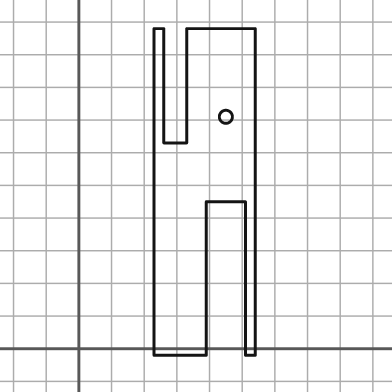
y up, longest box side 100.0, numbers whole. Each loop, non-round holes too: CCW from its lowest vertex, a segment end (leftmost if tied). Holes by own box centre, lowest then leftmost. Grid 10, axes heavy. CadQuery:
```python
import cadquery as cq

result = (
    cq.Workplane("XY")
    .moveTo(23.0, -2.0)
    .lineTo(39.0, -2.0)
    .lineTo(39.0, 45.0)
    .lineTo(51.0, 45.0)
    .lineTo(51.0, -2.0)
    .lineTo(54.0, -2.0)
    .lineTo(54.0, 98.0)
    .lineTo(33.0, 98.0)
    .lineTo(33.0, 63.0)
    .lineTo(26.0, 63.0)
    .lineTo(26.0, 98.0)
    .lineTo(23.0, 98.0)
    .close()
    .moveTo(45.0, 71.0)
    .circle(2.0)
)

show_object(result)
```